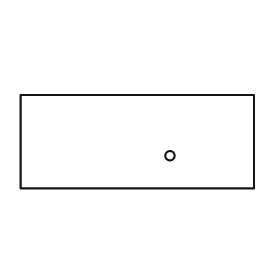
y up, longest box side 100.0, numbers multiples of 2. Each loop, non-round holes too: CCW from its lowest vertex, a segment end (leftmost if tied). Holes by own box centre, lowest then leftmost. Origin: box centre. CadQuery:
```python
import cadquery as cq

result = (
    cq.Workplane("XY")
    .moveTo(-50.0, -20.0)
    .lineTo(50.0, -20.0)
    .lineTo(50.0, 20.0)
    .lineTo(-50.0, 20.0)
    .close()
    .moveTo(14.0, -6.0)
    .circle(2.0)
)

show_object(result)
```